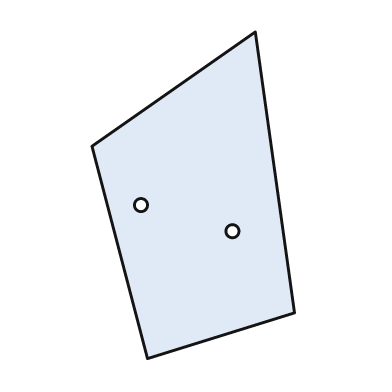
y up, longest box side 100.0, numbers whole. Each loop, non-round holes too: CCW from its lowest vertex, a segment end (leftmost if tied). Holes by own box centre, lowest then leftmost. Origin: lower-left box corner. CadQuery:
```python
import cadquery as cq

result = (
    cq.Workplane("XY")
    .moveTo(17.0, 0.0)
    .lineTo(62.0, 14.0)
    .lineTo(50.0, 100.0)
    .lineTo(0.0, 65.0)
    .close()
    .moveTo(43.0, 39.0)
    .circle(2.0)
    .moveTo(15.0, 47.0)
    .circle(2.0)
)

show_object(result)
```